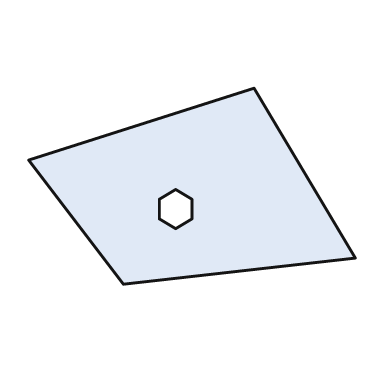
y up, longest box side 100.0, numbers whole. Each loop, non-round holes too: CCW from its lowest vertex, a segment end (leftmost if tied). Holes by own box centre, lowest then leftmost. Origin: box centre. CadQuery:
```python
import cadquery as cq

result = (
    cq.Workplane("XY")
    .moveTo(-21.0, -30.0)
    .lineTo(50.0, -22.0)
    .lineTo(19.0, 30.0)
    .lineTo(-50.0, 8.0)
    .close()
    .moveTo(-5.0, -13.0)
    .lineTo(0.0, -10.0)
    .lineTo(0.0, -4.0)
    .lineTo(-5.0, -1.0)
    .lineTo(-10.0, -4.0)
    .lineTo(-10.0, -10.0)
    .close()
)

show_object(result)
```